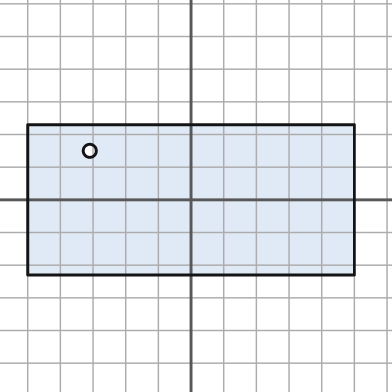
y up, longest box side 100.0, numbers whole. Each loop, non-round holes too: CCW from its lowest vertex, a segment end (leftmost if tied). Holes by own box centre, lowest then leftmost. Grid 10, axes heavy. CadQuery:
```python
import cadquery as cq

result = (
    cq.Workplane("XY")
    .moveTo(-50.0, -23.0)
    .lineTo(50.0, -23.0)
    .lineTo(50.0, 23.0)
    .lineTo(-50.0, 23.0)
    .close()
    .moveTo(-31.0, 15.0)
    .circle(2.0)
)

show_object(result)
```